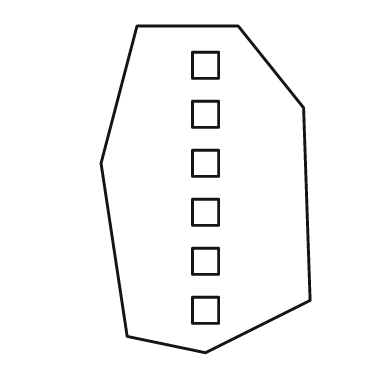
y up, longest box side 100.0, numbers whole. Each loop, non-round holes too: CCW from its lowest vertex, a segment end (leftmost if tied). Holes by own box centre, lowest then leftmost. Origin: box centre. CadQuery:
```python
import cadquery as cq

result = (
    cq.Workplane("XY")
    .moveTo(0.0, -50.0)
    .lineTo(32.0, -34.0)
    .lineTo(30.0, 25.0)
    .lineTo(10.0, 50.0)
    .lineTo(-21.0, 50.0)
    .lineTo(-32.0, 8.0)
    .lineTo(-24.0, -45.0)
    .close()
    .moveTo(-4.0, -41.0)
    .lineTo(4.0, -41.0)
    .lineTo(4.0, -33.0)
    .lineTo(-4.0, -33.0)
    .close()
    .moveTo(-4.0, -26.0)
    .lineTo(4.0, -26.0)
    .lineTo(4.0, -18.0)
    .lineTo(-4.0, -18.0)
    .close()
    .moveTo(-4.0, -11.0)
    .lineTo(4.0, -11.0)
    .lineTo(4.0, -3.0)
    .lineTo(-4.0, -3.0)
    .close()
    .moveTo(-4.0, 4.0)
    .lineTo(4.0, 4.0)
    .lineTo(4.0, 12.0)
    .lineTo(-4.0, 12.0)
    .close()
    .moveTo(-4.0, 19.0)
    .lineTo(4.0, 19.0)
    .lineTo(4.0, 27.0)
    .lineTo(-4.0, 27.0)
    .close()
    .moveTo(-4.0, 34.0)
    .lineTo(4.0, 34.0)
    .lineTo(4.0, 42.0)
    .lineTo(-4.0, 42.0)
    .close()
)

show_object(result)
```